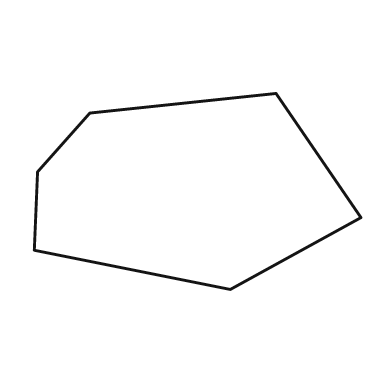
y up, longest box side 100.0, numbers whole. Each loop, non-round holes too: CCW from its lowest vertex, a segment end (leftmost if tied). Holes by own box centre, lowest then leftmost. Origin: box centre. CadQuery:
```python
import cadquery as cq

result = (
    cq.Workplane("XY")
    .moveTo(10.0, -30.0)
    .lineTo(50.0, -8.0)
    .lineTo(24.0, 30.0)
    .lineTo(-33.0, 24.0)
    .lineTo(-49.0, 6.0)
    .lineTo(-50.0, -18.0)
    .close()
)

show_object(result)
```